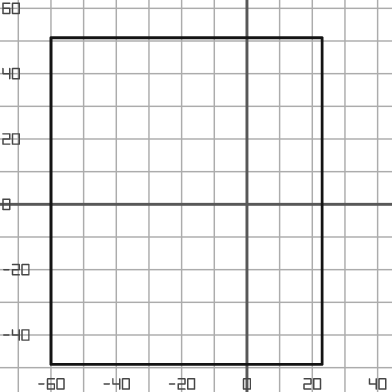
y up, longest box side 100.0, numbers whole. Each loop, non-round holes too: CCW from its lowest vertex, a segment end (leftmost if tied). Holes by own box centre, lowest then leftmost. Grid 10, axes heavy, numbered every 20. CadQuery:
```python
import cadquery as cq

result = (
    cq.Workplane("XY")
    .moveTo(-60.0, -49.0)
    .lineTo(23.0, -49.0)
    .lineTo(23.0, 51.0)
    .lineTo(-60.0, 51.0)
    .close()
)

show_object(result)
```